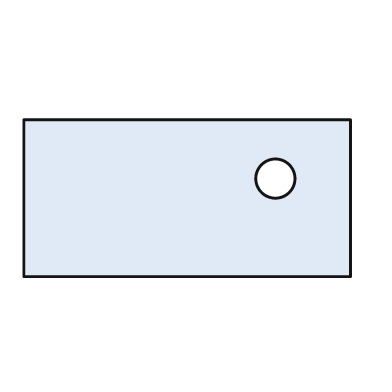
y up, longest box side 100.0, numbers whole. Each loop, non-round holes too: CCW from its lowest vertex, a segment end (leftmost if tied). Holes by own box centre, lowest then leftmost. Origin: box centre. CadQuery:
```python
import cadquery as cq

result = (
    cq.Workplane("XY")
    .moveTo(-50.0, -24.0)
    .lineTo(50.0, -24.0)
    .lineTo(50.0, 24.0)
    .lineTo(-50.0, 24.0)
    .close()
    .moveTo(27.0, 6.0)
    .circle(6.0)
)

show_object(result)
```